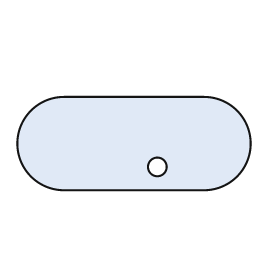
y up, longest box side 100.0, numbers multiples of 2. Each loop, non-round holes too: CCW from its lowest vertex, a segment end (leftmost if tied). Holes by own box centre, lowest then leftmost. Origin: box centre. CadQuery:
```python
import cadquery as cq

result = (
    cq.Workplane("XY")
    .moveTo(-30.0, -20.0)
    .lineTo(30.0, -20.0)
    .threePointArc((50.0, 0.0), (30.0, 20.0))
    .lineTo(-30.0, 20.0)
    .threePointArc((-50.0, 0.0), (-30.0, -20.0))
    .close()
    .moveTo(10.0, -10.0)
    .circle(4.0)
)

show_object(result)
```